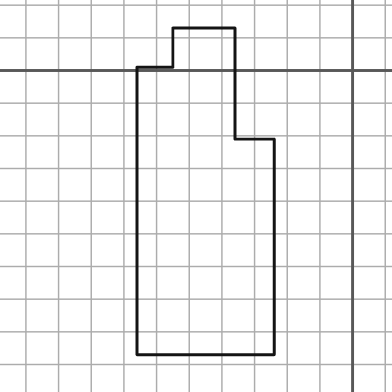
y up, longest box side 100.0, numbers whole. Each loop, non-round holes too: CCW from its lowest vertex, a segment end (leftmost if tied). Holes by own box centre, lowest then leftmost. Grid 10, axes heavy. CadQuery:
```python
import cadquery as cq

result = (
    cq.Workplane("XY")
    .moveTo(-66.0, -87.0)
    .lineTo(-24.0, -87.0)
    .lineTo(-24.0, -21.0)
    .lineTo(-36.0, -21.0)
    .lineTo(-36.0, 13.0)
    .lineTo(-55.0, 13.0)
    .lineTo(-55.0, 1.0)
    .lineTo(-66.0, 1.0)
    .close()
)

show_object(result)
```